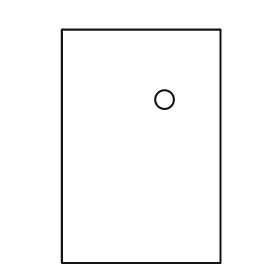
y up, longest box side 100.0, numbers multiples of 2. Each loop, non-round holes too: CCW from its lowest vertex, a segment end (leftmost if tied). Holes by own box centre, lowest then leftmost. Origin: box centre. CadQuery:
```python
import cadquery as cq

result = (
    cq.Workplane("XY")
    .moveTo(-34.0, -50.0)
    .lineTo(34.0, -50.0)
    .lineTo(34.0, 50.0)
    .lineTo(-34.0, 50.0)
    .close()
    .moveTo(10.0, 20.0)
    .circle(4.0)
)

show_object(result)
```